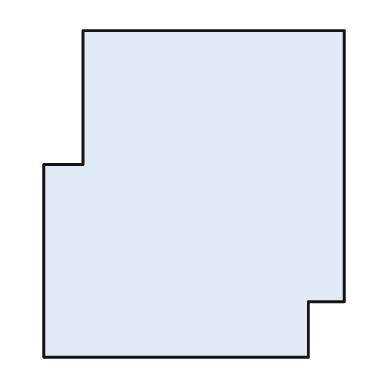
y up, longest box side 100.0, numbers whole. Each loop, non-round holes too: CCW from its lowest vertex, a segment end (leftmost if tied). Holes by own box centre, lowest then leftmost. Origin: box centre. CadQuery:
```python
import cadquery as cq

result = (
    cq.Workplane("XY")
    .moveTo(-46.0, -50.0)
    .lineTo(35.0, -50.0)
    .lineTo(35.0, -33.0)
    .lineTo(46.0, -33.0)
    .lineTo(46.0, 50.0)
    .lineTo(-34.0, 50.0)
    .lineTo(-34.0, 9.0)
    .lineTo(-46.0, 9.0)
    .close()
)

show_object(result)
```